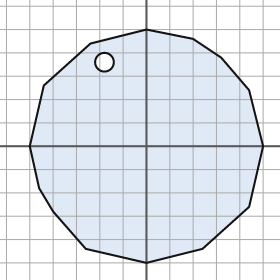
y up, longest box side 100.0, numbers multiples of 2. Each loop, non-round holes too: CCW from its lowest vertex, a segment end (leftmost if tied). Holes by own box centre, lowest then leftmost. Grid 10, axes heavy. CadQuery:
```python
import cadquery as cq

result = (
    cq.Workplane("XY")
    .moveTo(0.0, -50.0)
    .lineTo(24.0, -44.0)
    .lineTo(44.0, -26.0)
    .lineTo(50.0, 0.0)
    .lineTo(44.0, 24.0)
    .lineTo(32.0, 38.0)
    .lineTo(20.0, 46.0)
    .lineTo(0.0, 50.0)
    .lineTo(-24.0, 44.0)
    .lineTo(-44.0, 26.0)
    .lineTo(-50.0, 0.0)
    .lineTo(-46.0, -18.0)
    .lineTo(-40.0, -28.0)
    .lineTo(-26.0, -44.0)
    .close()
    .moveTo(-18.0, 36.0)
    .circle(4.0)
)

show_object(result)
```